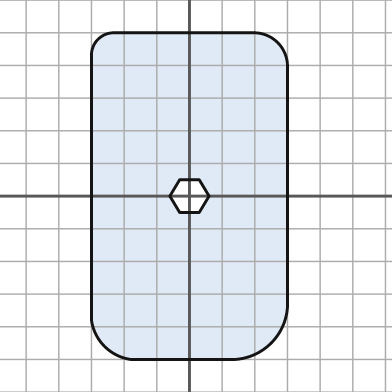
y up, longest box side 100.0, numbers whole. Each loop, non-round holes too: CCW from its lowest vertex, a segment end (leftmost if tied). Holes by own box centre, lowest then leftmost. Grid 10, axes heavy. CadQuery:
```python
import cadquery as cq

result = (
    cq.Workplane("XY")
    .moveTo(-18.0, -50.0)
    .lineTo(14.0, -50.0)
    .threePointArc((25.0, -45.0), (30.0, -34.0))
    .lineTo(30.0, 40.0)
    .threePointArc((27.0, 47.0), (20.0, 50.0))
    .lineTo(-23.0, 50.0)
    .threePointArc((-28.0, 48.0), (-30.0, 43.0))
    .lineTo(-30.0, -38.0)
    .threePointArc((-26.0, -46.0), (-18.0, -50.0))
    .close()
    .moveTo(-3.0, -5.0)
    .lineTo(3.0, -5.0)
    .lineTo(6.0, 0.0)
    .lineTo(3.0, 5.0)
    .lineTo(-3.0, 5.0)
    .lineTo(-6.0, 0.0)
    .close()
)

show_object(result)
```